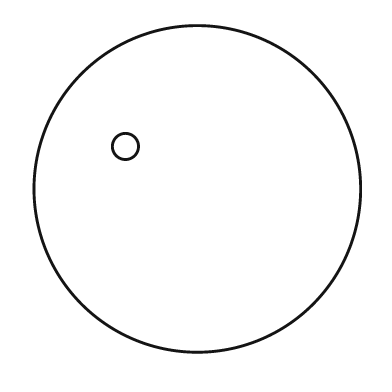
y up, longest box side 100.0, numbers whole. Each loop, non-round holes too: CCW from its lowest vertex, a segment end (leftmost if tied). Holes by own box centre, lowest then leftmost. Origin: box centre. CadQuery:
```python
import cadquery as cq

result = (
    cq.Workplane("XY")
    .moveTo(0.0, 0.0)
    .circle(50.0)
    .moveTo(-22.0, 13.0)
    .circle(4.0)
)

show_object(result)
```